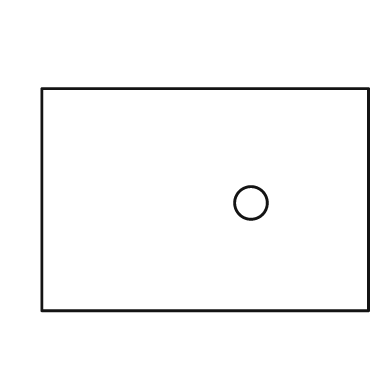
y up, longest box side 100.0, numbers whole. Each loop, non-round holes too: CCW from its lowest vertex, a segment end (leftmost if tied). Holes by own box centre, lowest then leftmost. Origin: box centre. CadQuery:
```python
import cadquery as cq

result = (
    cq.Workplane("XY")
    .moveTo(-50.0, -34.0)
    .lineTo(50.0, -34.0)
    .lineTo(50.0, 34.0)
    .lineTo(-50.0, 34.0)
    .close()
    .moveTo(14.0, -1.0)
    .circle(5.0)
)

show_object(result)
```